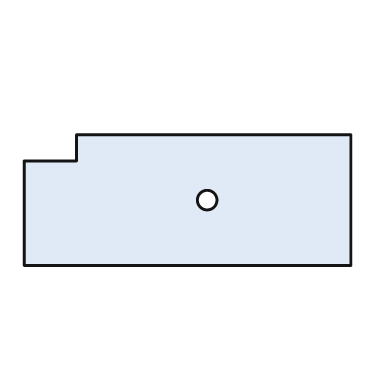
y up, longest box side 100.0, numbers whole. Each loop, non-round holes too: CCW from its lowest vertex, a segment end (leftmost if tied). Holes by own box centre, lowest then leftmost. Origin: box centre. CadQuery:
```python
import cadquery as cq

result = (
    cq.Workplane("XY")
    .moveTo(-50.0, -20.0)
    .lineTo(50.0, -20.0)
    .lineTo(50.0, 20.0)
    .lineTo(-34.0, 20.0)
    .lineTo(-34.0, 12.0)
    .lineTo(-50.0, 12.0)
    .close()
    .moveTo(6.0, 0.0)
    .circle(3.0)
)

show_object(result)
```